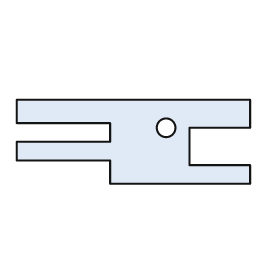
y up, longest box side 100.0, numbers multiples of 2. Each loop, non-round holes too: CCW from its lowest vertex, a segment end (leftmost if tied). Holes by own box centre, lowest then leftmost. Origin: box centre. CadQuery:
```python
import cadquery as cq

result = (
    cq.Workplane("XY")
    .moveTo(-10.0, -18.0)
    .lineTo(50.0, -18.0)
    .lineTo(50.0, -10.0)
    .lineTo(24.0, -10.0)
    .lineTo(24.0, 6.0)
    .lineTo(50.0, 6.0)
    .lineTo(50.0, 18.0)
    .lineTo(-50.0, 18.0)
    .lineTo(-50.0, 8.0)
    .lineTo(-10.0, 8.0)
    .lineTo(-10.0, 0.0)
    .lineTo(-50.0, 0.0)
    .lineTo(-50.0, -8.0)
    .lineTo(-10.0, -8.0)
    .close()
    .moveTo(14.0, 6.0)
    .circle(4.0)
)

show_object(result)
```